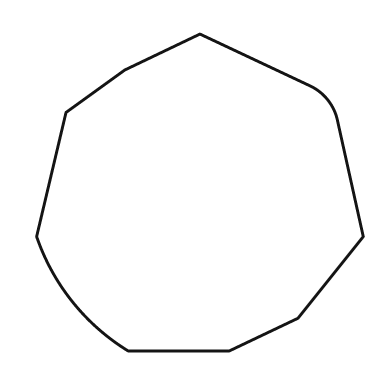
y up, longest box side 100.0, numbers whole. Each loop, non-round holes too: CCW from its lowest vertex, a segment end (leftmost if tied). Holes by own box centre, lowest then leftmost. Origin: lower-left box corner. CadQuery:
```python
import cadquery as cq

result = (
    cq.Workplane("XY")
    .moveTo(28.0, 0.0)
    .lineTo(59.0, 0.0)
    .lineTo(80.0, 10.0)
    .lineTo(100.0, 35.0)
    .lineTo(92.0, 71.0)
    .threePointArc((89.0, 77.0), (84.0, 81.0))
    .lineTo(50.0, 97.0)
    .lineTo(27.0, 86.0)
    .lineTo(9.0, 73.0)
    .lineTo(0.0, 35.0)
    .threePointArc((11.0, 15.0), (28.0, 0.0))
    .close()
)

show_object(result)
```